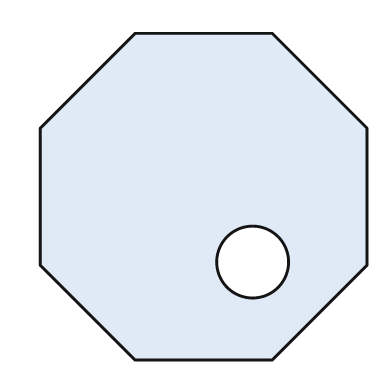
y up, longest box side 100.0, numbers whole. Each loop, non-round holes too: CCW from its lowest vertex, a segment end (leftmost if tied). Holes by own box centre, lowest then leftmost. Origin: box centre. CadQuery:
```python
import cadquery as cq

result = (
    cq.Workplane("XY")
    .moveTo(-21.0, -50.0)
    .lineTo(21.0, -50.0)
    .lineTo(50.0, -21.0)
    .lineTo(50.0, 21.0)
    .lineTo(21.0, 50.0)
    .lineTo(-21.0, 50.0)
    .lineTo(-50.0, 21.0)
    .lineTo(-50.0, -21.0)
    .close()
    .moveTo(15.0, -20.0)
    .circle(11.0)
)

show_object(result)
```